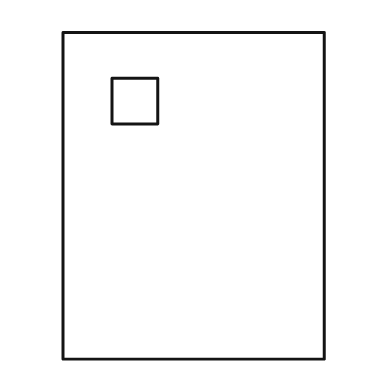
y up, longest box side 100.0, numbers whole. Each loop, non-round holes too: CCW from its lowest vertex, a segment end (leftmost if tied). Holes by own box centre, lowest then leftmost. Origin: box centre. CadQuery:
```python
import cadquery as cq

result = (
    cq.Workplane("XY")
    .moveTo(-40.0, -50.0)
    .lineTo(40.0, -50.0)
    .lineTo(40.0, 50.0)
    .lineTo(-40.0, 50.0)
    .close()
    .moveTo(-25.0, 22.0)
    .lineTo(-11.0, 22.0)
    .lineTo(-11.0, 36.0)
    .lineTo(-25.0, 36.0)
    .close()
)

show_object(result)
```